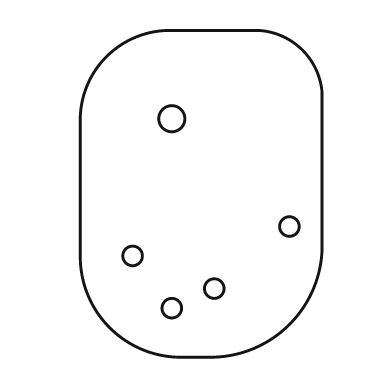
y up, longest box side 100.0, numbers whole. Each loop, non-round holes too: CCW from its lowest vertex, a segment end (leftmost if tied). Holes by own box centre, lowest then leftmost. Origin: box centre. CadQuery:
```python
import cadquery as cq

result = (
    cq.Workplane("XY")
    .moveTo(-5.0, -50.0)
    .lineTo(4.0, -50.0)
    .threePointArc((27.0, -40.0), (37.0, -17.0))
    .lineTo(37.0, 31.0)
    .threePointArc((31.0, 44.0), (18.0, 50.0))
    .lineTo(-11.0, 50.0)
    .threePointArc((-29.0, 42.0), (-37.0, 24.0))
    .lineTo(-37.0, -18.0)
    .threePointArc((-28.0, -41.0), (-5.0, -50.0))
    .close()
    .moveTo(-9.0, -35.0)
    .circle(3.0)
    .moveTo(4.0, -29.0)
    .circle(3.0)
    .moveTo(-21.0, -19.0)
    .circle(3.0)
    .moveTo(27.0, -10.0)
    .circle(3.0)
    .moveTo(-9.0, 23.0)
    .circle(4.0)
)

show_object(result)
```